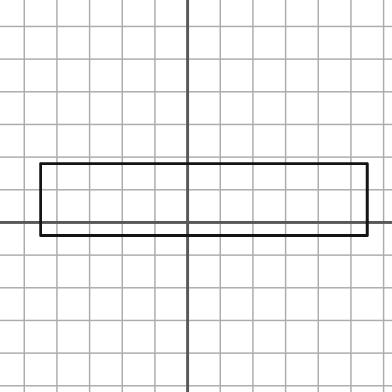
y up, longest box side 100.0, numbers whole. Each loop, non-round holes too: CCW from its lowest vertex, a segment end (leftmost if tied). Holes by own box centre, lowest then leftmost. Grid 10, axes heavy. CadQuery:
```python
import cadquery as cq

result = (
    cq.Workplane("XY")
    .moveTo(-45.0, -4.0)
    .lineTo(55.0, -4.0)
    .lineTo(55.0, 18.0)
    .lineTo(-45.0, 18.0)
    .close()
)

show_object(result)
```